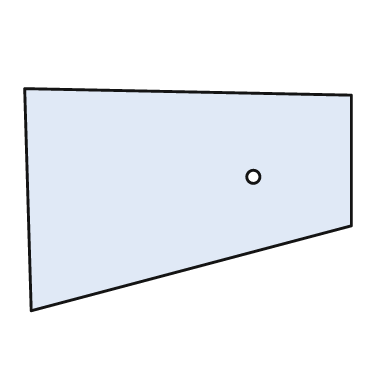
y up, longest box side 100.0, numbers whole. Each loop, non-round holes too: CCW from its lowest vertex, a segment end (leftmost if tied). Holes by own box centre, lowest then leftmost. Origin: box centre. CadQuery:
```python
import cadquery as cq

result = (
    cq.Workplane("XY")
    .moveTo(-48.0, -34.0)
    .lineTo(50.0, -8.0)
    .lineTo(50.0, 32.0)
    .lineTo(-50.0, 34.0)
    .close()
    .moveTo(20.0, 7.0)
    .circle(2.0)
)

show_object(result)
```